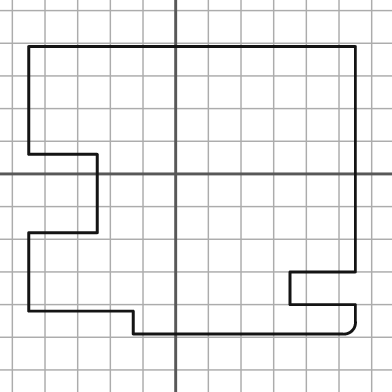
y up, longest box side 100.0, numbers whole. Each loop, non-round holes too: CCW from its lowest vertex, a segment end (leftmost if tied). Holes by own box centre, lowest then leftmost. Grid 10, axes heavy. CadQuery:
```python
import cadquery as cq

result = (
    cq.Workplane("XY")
    .moveTo(-13.0, -49.0)
    .lineTo(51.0, -49.0)
    .threePointArc((54.0, -48.0), (55.0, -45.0))
    .lineTo(55.0, -40.0)
    .lineTo(35.0, -40.0)
    .lineTo(35.0, -30.0)
    .lineTo(55.0, -30.0)
    .lineTo(55.0, 39.0)
    .lineTo(-45.0, 39.0)
    .lineTo(-45.0, 6.0)
    .lineTo(-24.0, 6.0)
    .lineTo(-24.0, -18.0)
    .lineTo(-45.0, -18.0)
    .lineTo(-45.0, -42.0)
    .lineTo(-13.0, -42.0)
    .close()
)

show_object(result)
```